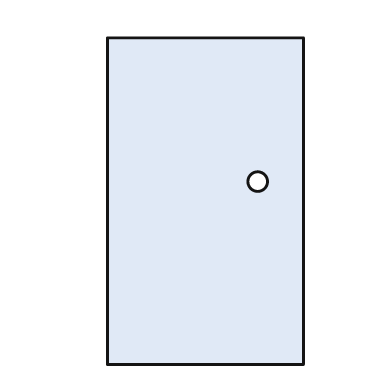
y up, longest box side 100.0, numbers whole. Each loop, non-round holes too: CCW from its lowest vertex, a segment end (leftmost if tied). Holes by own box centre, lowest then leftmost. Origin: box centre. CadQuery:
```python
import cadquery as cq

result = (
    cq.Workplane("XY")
    .moveTo(-30.0, -50.0)
    .lineTo(30.0, -50.0)
    .lineTo(30.0, 50.0)
    .lineTo(-30.0, 50.0)
    .close()
    .moveTo(16.0, 6.0)
    .circle(3.0)
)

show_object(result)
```